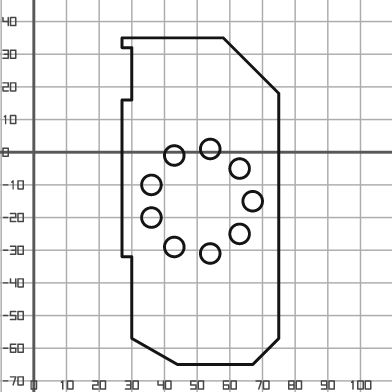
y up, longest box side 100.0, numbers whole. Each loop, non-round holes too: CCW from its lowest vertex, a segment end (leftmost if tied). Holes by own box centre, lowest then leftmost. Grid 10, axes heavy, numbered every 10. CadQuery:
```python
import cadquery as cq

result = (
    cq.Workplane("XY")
    .moveTo(44.0, -65.0)
    .lineTo(67.0, -65.0)
    .lineTo(75.0, -57.0)
    .lineTo(75.0, 18.0)
    .lineTo(58.0, 35.0)
    .lineTo(27.0, 35.0)
    .lineTo(27.0, 32.0)
    .lineTo(30.0, 32.0)
    .lineTo(30.0, 16.0)
    .lineTo(27.0, 16.0)
    .lineTo(27.0, -32.0)
    .lineTo(30.0, -32.0)
    .lineTo(30.0, -57.0)
    .close()
    .moveTo(54.0, -31.0)
    .circle(3.0)
    .moveTo(43.0, -29.0)
    .circle(3.0)
    .moveTo(63.0, -25.0)
    .circle(3.0)
    .moveTo(36.0, -20.0)
    .circle(3.0)
    .moveTo(67.0, -15.0)
    .circle(3.0)
    .moveTo(36.0, -10.0)
    .circle(3.0)
    .moveTo(63.0, -5.0)
    .circle(3.0)
    .moveTo(43.0, -1.0)
    .circle(3.0)
    .moveTo(54.0, 1.0)
    .circle(3.0)
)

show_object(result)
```